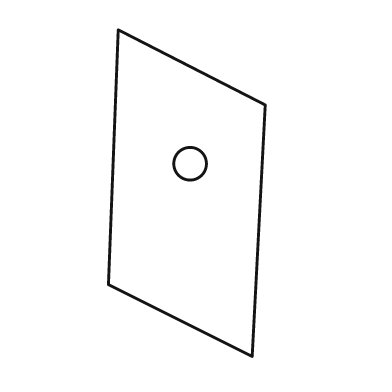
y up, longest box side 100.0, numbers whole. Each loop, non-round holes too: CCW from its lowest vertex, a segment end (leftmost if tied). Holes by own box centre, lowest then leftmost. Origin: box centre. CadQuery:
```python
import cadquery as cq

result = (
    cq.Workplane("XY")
    .moveTo(20.0, -50.0)
    .lineTo(24.0, 27.0)
    .lineTo(-21.0, 50.0)
    .lineTo(-24.0, -28.0)
    .close()
    .moveTo(1.0, 9.0)
    .circle(5.0)
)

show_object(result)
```